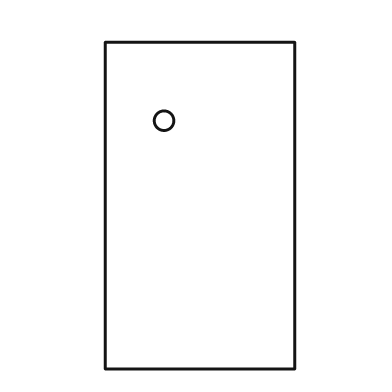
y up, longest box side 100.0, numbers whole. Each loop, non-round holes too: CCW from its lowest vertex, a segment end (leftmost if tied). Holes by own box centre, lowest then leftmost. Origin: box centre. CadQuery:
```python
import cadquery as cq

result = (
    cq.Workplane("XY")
    .moveTo(-29.0, -50.0)
    .lineTo(29.0, -50.0)
    .lineTo(29.0, 50.0)
    .lineTo(-29.0, 50.0)
    .close()
    .moveTo(-11.0, 26.0)
    .circle(3.0)
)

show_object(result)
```